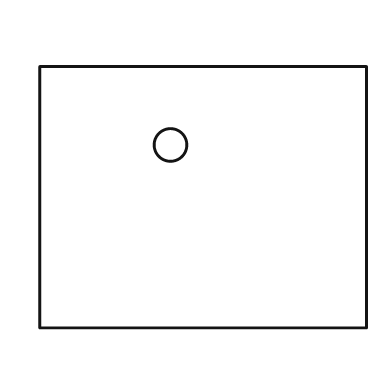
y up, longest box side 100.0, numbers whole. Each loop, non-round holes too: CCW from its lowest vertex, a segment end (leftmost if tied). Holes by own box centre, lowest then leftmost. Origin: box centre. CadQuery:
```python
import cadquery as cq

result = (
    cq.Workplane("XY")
    .moveTo(-50.0, -40.0)
    .lineTo(50.0, -40.0)
    .lineTo(50.0, 40.0)
    .lineTo(-50.0, 40.0)
    .close()
    .moveTo(-10.0, 16.0)
    .circle(5.0)
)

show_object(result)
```